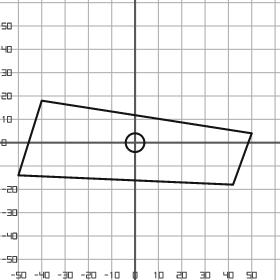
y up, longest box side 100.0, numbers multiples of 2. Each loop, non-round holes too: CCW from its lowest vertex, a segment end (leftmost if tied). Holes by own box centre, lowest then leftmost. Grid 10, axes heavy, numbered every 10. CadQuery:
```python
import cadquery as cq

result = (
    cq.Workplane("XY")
    .moveTo(42.0, -18.0)
    .lineTo(50.0, 4.0)
    .lineTo(-40.0, 18.0)
    .lineTo(-50.0, -14.0)
    .close()
    .moveTo(0.0, 0.0)
    .circle(4.0)
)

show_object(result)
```